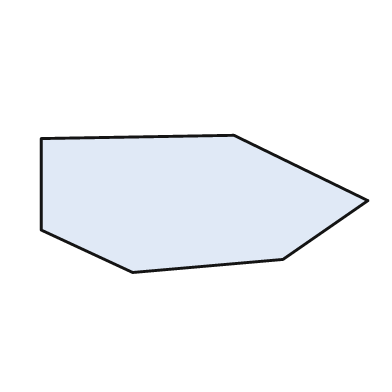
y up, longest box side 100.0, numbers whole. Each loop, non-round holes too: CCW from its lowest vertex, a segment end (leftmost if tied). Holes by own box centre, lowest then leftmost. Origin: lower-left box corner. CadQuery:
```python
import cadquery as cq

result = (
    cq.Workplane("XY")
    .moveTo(28.0, 0.0)
    .lineTo(74.0, 4.0)
    .lineTo(100.0, 22.0)
    .lineTo(59.0, 42.0)
    .lineTo(0.0, 41.0)
    .lineTo(0.0, 13.0)
    .close()
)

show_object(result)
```